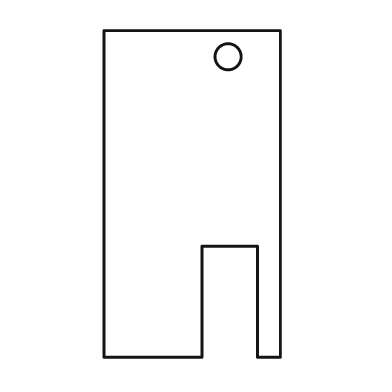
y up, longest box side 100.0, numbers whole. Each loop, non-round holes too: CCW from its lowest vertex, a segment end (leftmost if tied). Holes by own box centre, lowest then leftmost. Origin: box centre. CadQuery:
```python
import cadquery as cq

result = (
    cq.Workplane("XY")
    .moveTo(-27.0, -50.0)
    .lineTo(3.0, -50.0)
    .lineTo(3.0, -16.0)
    .lineTo(20.0, -16.0)
    .lineTo(20.0, -50.0)
    .lineTo(27.0, -50.0)
    .lineTo(27.0, 50.0)
    .lineTo(-27.0, 50.0)
    .close()
    .moveTo(11.0, 42.0)
    .circle(4.0)
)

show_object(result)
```